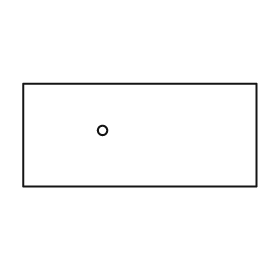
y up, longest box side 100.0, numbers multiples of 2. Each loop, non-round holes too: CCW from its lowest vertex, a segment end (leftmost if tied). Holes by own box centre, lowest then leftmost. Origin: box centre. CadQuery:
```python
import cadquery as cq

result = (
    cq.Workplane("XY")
    .moveTo(-50.0, -22.0)
    .lineTo(50.0, -22.0)
    .lineTo(50.0, 22.0)
    .lineTo(-50.0, 22.0)
    .close()
    .moveTo(-16.0, 2.0)
    .circle(2.0)
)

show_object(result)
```